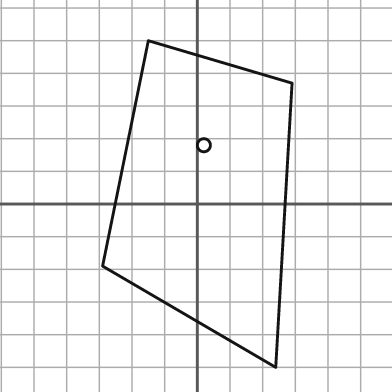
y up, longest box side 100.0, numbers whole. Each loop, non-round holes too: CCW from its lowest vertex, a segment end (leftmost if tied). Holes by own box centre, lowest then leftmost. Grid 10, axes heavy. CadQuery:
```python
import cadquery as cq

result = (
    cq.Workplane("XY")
    .moveTo(24.0, -50.0)
    .lineTo(29.0, 37.0)
    .lineTo(-15.0, 50.0)
    .lineTo(-29.0, -19.0)
    .close()
    .moveTo(2.0, 18.0)
    .circle(2.0)
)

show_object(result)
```